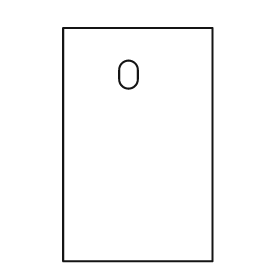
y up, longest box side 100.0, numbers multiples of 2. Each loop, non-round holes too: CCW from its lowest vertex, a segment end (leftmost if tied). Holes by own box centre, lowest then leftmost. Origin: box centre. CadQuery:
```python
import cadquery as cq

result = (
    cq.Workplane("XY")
    .moveTo(-32.0, -50.0)
    .lineTo(32.0, -50.0)
    .lineTo(32.0, 50.0)
    .lineTo(-32.0, 50.0)
    .close()
    .moveTo(-8.0, 28.0)
    .threePointArc((-4.0, 24.0), (0.0, 28.0))
    .lineTo(0.0, 32.0)
    .threePointArc((-4.0, 36.0), (-8.0, 32.0))
    .close()
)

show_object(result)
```